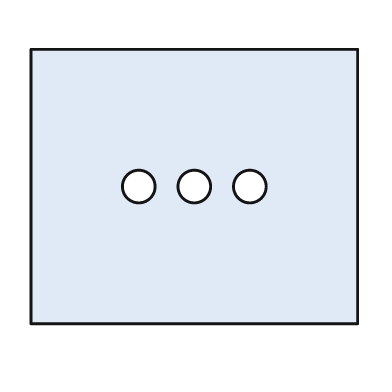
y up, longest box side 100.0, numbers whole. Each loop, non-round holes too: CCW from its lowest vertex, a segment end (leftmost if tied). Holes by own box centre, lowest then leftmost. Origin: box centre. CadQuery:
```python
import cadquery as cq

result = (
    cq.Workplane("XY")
    .moveTo(-50.0, -42.0)
    .lineTo(50.0, -42.0)
    .lineTo(50.0, 42.0)
    .lineTo(-50.0, 42.0)
    .close()
    .moveTo(-17.0, 0.0)
    .circle(5.0)
    .moveTo(0.0, 0.0)
    .circle(5.0)
    .moveTo(17.0, 0.0)
    .circle(5.0)
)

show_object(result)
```